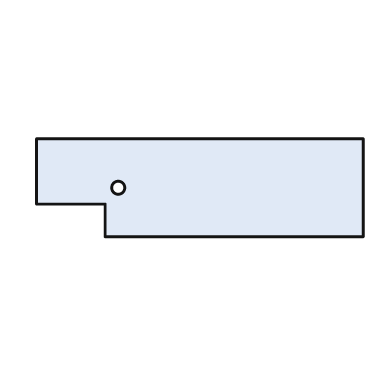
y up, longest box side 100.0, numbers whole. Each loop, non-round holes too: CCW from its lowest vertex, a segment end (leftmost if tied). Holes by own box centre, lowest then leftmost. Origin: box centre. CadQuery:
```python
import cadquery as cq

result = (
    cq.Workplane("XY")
    .moveTo(-29.0, -15.0)
    .lineTo(50.0, -15.0)
    .lineTo(50.0, 15.0)
    .lineTo(-50.0, 15.0)
    .lineTo(-50.0, -5.0)
    .lineTo(-29.0, -5.0)
    .close()
    .moveTo(-25.0, 0.0)
    .circle(2.0)
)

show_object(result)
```